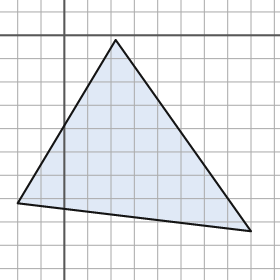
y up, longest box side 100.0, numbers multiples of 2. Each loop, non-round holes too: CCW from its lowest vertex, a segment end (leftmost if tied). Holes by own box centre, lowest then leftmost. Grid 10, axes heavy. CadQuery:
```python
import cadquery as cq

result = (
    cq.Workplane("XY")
    .moveTo(80.0, -84.0)
    .lineTo(22.0, -2.0)
    .lineTo(-20.0, -72.0)
    .close()
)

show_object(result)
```